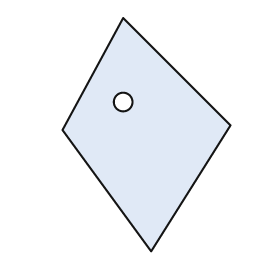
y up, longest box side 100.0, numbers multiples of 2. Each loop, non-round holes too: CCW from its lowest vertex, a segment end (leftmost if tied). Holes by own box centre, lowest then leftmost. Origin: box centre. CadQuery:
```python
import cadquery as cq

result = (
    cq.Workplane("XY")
    .moveTo(2.0, -50.0)
    .lineTo(36.0, 4.0)
    .lineTo(-10.0, 50.0)
    .lineTo(-36.0, 2.0)
    .close()
    .moveTo(-10.0, 14.0)
    .circle(4.0)
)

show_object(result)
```